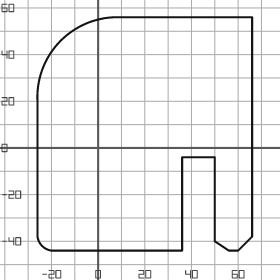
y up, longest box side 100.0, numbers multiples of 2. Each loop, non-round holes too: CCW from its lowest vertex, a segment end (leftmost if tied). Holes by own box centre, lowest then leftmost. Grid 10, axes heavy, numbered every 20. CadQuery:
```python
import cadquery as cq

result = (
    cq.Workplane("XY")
    .moveTo(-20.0, -44.0)
    .lineTo(36.0, -44.0)
    .lineTo(36.0, -4.0)
    .lineTo(50.0, -4.0)
    .lineTo(50.0, -40.0)
    .lineTo(56.0, -44.0)
    .lineTo(60.0, -44.0)
    .lineTo(66.0, -38.0)
    .lineTo(66.0, 56.0)
    .lineTo(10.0, 56.0)
    .threePointArc((-16.0, 46.0), (-26.0, 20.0))
    .lineTo(-26.0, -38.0)
    .threePointArc((-24.0, -42.0), (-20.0, -44.0))
    .close()
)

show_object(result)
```